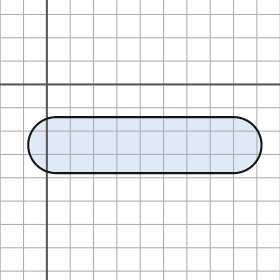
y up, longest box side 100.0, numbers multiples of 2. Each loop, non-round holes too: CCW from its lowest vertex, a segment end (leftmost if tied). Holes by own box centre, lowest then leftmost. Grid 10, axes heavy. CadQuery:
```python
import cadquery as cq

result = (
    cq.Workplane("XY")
    .moveTo(4.0, -38.0)
    .lineTo(80.0, -38.0)
    .threePointArc((92.0, -26.0), (80.0, -14.0))
    .lineTo(4.0, -14.0)
    .threePointArc((-8.0, -26.0), (4.0, -38.0))
    .close()
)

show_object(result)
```